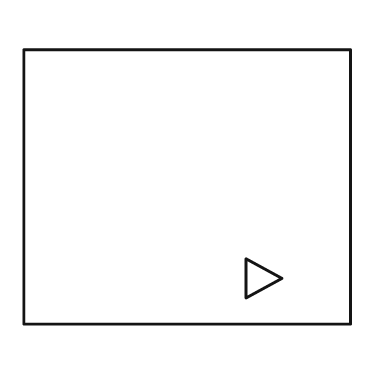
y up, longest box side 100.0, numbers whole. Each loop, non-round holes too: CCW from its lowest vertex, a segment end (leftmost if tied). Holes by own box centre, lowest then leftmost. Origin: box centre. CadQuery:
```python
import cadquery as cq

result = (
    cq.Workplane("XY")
    .moveTo(-50.0, -42.0)
    .lineTo(50.0, -42.0)
    .lineTo(50.0, 42.0)
    .lineTo(-50.0, 42.0)
    .close()
    .moveTo(18.0, -34.0)
    .lineTo(29.0, -28.0)
    .lineTo(18.0, -22.0)
    .close()
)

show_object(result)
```